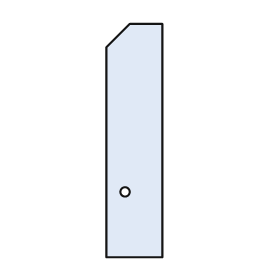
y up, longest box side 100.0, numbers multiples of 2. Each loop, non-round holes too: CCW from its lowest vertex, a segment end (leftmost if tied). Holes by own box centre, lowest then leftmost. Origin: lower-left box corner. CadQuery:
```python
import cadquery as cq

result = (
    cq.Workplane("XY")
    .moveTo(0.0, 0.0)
    .lineTo(24.0, 0.0)
    .lineTo(24.0, 100.0)
    .lineTo(10.0, 100.0)
    .lineTo(0.0, 90.0)
    .close()
    .moveTo(8.0, 28.0)
    .circle(2.0)
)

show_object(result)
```